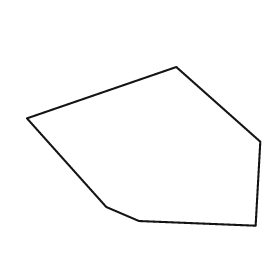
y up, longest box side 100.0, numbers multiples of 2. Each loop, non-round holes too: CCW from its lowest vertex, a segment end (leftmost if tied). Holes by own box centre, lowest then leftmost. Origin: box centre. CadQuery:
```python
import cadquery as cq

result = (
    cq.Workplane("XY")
    .moveTo(48.0, -34.0)
    .lineTo(50.0, 2.0)
    .lineTo(14.0, 34.0)
    .lineTo(-50.0, 12.0)
    .lineTo(-16.0, -26.0)
    .lineTo(-2.0, -32.0)
    .close()
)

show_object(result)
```